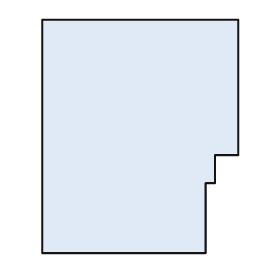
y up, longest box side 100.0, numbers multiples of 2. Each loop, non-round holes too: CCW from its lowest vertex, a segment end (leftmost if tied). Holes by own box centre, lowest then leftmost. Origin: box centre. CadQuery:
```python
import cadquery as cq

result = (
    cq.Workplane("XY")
    .moveTo(-42.0, -50.0)
    .lineTo(28.0, -50.0)
    .lineTo(28.0, -20.0)
    .lineTo(32.0, -20.0)
    .lineTo(32.0, -8.0)
    .lineTo(42.0, -8.0)
    .lineTo(42.0, 50.0)
    .lineTo(-42.0, 50.0)
    .close()
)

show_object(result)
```